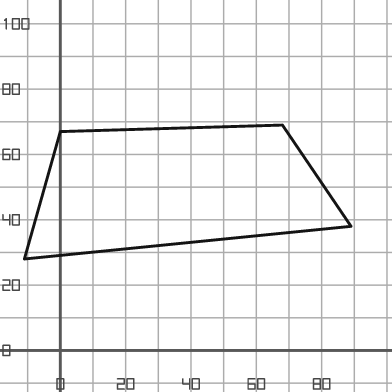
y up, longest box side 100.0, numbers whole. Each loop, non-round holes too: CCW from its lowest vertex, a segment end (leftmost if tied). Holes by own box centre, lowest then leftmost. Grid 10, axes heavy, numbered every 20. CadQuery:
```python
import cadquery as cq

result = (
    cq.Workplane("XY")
    .moveTo(-11.0, 28.0)
    .lineTo(89.0, 38.0)
    .lineTo(68.0, 69.0)
    .lineTo(0.0, 67.0)
    .close()
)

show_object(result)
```